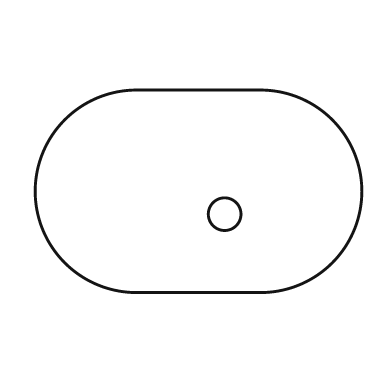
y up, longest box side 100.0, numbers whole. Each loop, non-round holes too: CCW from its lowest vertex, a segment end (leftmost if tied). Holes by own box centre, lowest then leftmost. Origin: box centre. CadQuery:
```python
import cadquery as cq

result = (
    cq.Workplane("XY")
    .moveTo(-19.0, -31.0)
    .lineTo(19.0, -31.0)
    .threePointArc((50.0, 0.0), (19.0, 31.0))
    .lineTo(-19.0, 31.0)
    .threePointArc((-50.0, 0.0), (-19.0, -31.0))
    .close()
    .moveTo(8.0, -7.0)
    .circle(5.0)
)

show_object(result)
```